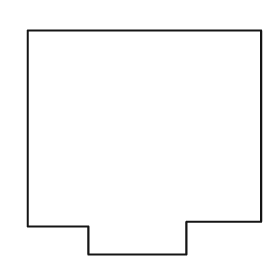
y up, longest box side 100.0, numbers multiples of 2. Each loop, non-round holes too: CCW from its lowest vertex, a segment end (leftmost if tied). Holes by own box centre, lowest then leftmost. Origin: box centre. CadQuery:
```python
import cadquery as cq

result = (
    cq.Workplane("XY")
    .moveTo(-24.0, -48.0)
    .lineTo(18.0, -48.0)
    .lineTo(18.0, -34.0)
    .lineTo(50.0, -34.0)
    .lineTo(50.0, 48.0)
    .lineTo(-50.0, 48.0)
    .lineTo(-50.0, -36.0)
    .lineTo(-24.0, -36.0)
    .close()
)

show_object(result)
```